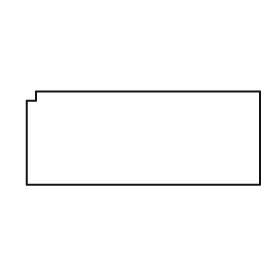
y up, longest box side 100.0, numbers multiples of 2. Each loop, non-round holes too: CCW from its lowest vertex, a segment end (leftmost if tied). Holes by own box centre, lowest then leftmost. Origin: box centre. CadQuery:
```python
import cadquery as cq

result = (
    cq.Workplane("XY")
    .moveTo(-50.0, -20.0)
    .lineTo(50.0, -20.0)
    .lineTo(50.0, 20.0)
    .lineTo(-46.0, 20.0)
    .lineTo(-46.0, 16.0)
    .lineTo(-50.0, 16.0)
    .close()
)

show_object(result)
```